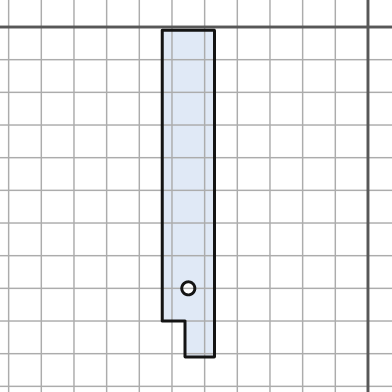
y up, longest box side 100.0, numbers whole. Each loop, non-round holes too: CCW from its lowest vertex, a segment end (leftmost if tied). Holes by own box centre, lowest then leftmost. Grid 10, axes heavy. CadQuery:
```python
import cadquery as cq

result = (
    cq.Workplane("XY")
    .moveTo(-56.0, -101.0)
    .lineTo(-47.0, -101.0)
    .lineTo(-47.0, -1.0)
    .lineTo(-63.0, -1.0)
    .lineTo(-63.0, -90.0)
    .lineTo(-56.0, -90.0)
    .close()
    .moveTo(-55.0, -80.0)
    .circle(2.0)
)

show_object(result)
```